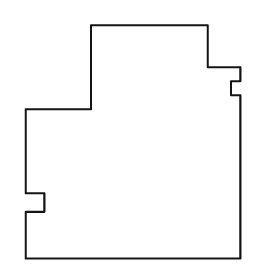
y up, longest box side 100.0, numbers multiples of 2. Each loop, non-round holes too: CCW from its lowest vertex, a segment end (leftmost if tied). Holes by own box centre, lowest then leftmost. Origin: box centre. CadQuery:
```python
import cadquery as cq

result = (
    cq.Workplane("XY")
    .moveTo(-46.0, -50.0)
    .lineTo(46.0, -50.0)
    .lineTo(46.0, 20.0)
    .lineTo(42.0, 20.0)
    .lineTo(42.0, 26.0)
    .lineTo(46.0, 26.0)
    .lineTo(46.0, 32.0)
    .lineTo(32.0, 32.0)
    .lineTo(32.0, 50.0)
    .lineTo(-18.0, 50.0)
    .lineTo(-18.0, 14.0)
    .lineTo(-46.0, 14.0)
    .lineTo(-46.0, -22.0)
    .lineTo(-38.0, -22.0)
    .lineTo(-38.0, -30.0)
    .lineTo(-46.0, -30.0)
    .close()
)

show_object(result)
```